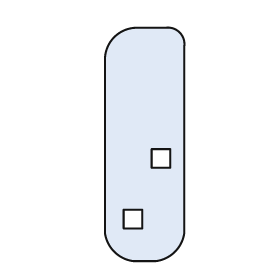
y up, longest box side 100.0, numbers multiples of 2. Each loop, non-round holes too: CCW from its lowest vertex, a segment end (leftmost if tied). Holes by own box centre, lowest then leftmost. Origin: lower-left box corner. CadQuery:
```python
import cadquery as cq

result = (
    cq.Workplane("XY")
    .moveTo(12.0, 0.0)
    .lineTo(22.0, 0.0)
    .threePointArc((30.0, 4.0), (34.0, 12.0))
    .lineTo(34.0, 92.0)
    .threePointArc((32.0, 98.0), (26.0, 100.0))
    .lineTo(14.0, 100.0)
    .threePointArc((4.0, 96.0), (0.0, 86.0))
    .lineTo(0.0, 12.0)
    .threePointArc((4.0, 4.0), (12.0, 0.0))
    .close()
    .moveTo(8.0, 14.0)
    .lineTo(16.0, 14.0)
    .lineTo(16.0, 22.0)
    .lineTo(8.0, 22.0)
    .close()
    .moveTo(20.0, 40.0)
    .lineTo(28.0, 40.0)
    .lineTo(28.0, 48.0)
    .lineTo(20.0, 48.0)
    .close()
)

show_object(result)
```